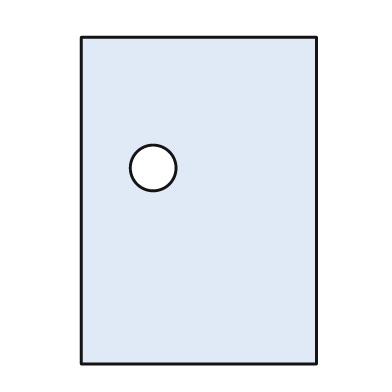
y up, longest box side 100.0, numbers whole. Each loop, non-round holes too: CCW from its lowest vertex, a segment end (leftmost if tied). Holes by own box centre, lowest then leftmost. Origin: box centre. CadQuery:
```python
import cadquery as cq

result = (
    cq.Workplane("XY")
    .moveTo(-36.0, -50.0)
    .lineTo(36.0, -50.0)
    .lineTo(36.0, 50.0)
    .lineTo(-36.0, 50.0)
    .close()
    .moveTo(-14.0, 10.0)
    .circle(7.0)
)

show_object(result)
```